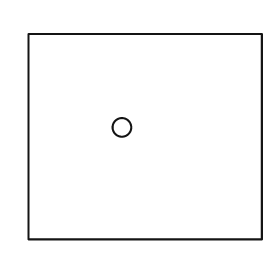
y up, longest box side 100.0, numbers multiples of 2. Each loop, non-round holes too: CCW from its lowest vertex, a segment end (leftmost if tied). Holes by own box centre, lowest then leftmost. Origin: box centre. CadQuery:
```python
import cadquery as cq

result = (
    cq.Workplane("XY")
    .moveTo(-50.0, -44.0)
    .lineTo(50.0, -44.0)
    .lineTo(50.0, 44.0)
    .lineTo(-50.0, 44.0)
    .close()
    .moveTo(-10.0, 4.0)
    .circle(4.0)
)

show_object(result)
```